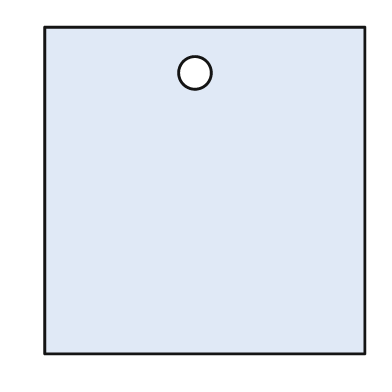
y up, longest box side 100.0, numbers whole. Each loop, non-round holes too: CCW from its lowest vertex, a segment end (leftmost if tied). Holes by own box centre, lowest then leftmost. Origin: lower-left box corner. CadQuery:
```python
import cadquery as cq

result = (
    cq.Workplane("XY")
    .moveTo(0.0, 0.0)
    .lineTo(98.0, 0.0)
    .lineTo(98.0, 100.0)
    .lineTo(0.0, 100.0)
    .close()
    .moveTo(46.0, 86.0)
    .circle(5.0)
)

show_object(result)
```